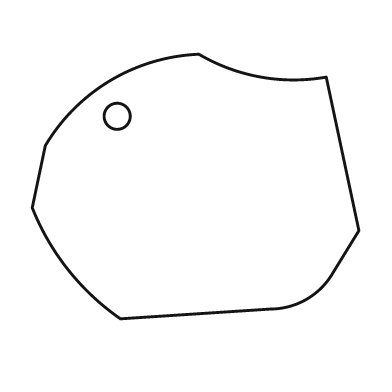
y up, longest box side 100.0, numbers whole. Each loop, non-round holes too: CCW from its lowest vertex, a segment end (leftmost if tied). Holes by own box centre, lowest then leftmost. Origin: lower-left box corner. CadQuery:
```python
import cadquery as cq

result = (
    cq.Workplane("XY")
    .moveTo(27.0, 0.0)
    .lineTo(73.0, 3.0)
    .threePointArc((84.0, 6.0), (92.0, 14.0))
    .lineTo(100.0, 27.0)
    .lineTo(90.0, 74.0)
    .threePointArc((70.0, 74.0), (51.0, 81.0))
    .threePointArc((24.0, 73.0), (4.0, 53.0))
    .lineTo(0.0, 34.0)
    .threePointArc((11.0, 15.0), (27.0, 0.0))
    .close()
    .moveTo(26.0, 62.0)
    .circle(4.0)
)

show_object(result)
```